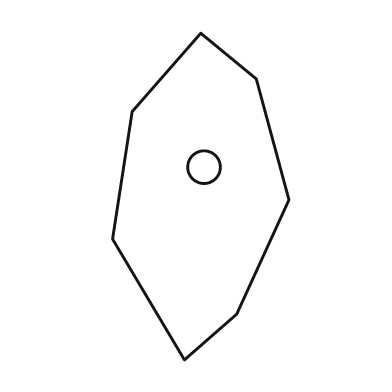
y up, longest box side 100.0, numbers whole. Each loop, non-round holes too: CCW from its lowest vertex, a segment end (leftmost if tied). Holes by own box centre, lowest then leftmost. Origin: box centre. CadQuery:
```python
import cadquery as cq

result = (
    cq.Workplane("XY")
    .moveTo(-5.0, -50.0)
    .lineTo(11.0, -36.0)
    .lineTo(27.0, -1.0)
    .lineTo(17.0, 36.0)
    .lineTo(0.0, 50.0)
    .lineTo(-21.0, 26.0)
    .lineTo(-27.0, -13.0)
    .close()
    .moveTo(1.0, 9.0)
    .circle(5.0)
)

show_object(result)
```